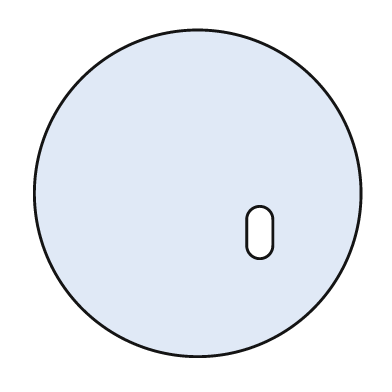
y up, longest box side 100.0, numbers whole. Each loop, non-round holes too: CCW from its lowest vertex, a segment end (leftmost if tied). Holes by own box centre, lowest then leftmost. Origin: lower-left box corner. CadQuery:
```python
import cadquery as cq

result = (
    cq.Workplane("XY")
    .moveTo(50.0, 50.0)
    .circle(50.0)
    .moveTo(65.0, 34.0)
    .threePointArc((69.0, 30.0), (73.0, 34.0))
    .lineTo(73.0, 42.0)
    .threePointArc((69.0, 46.0), (65.0, 42.0))
    .close()
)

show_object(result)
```